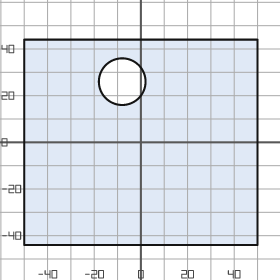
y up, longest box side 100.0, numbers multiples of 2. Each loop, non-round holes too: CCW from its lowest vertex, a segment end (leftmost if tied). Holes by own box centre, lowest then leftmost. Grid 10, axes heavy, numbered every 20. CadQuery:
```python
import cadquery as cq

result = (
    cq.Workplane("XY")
    .moveTo(-50.0, -44.0)
    .lineTo(50.0, -44.0)
    .lineTo(50.0, 44.0)
    .lineTo(-50.0, 44.0)
    .close()
    .moveTo(-8.0, 26.0)
    .circle(10.0)
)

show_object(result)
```